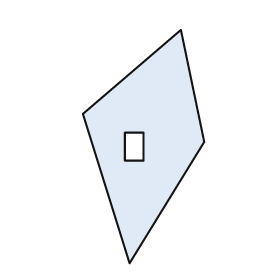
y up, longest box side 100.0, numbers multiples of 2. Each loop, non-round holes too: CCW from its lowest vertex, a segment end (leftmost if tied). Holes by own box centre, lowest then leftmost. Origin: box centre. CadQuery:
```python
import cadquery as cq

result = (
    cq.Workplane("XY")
    .moveTo(-6.0, -50.0)
    .lineTo(26.0, 2.0)
    .lineTo(16.0, 50.0)
    .lineTo(-26.0, 14.0)
    .close()
    .moveTo(-8.0, -6.0)
    .lineTo(0.0, -6.0)
    .lineTo(0.0, 6.0)
    .lineTo(-8.0, 6.0)
    .close()
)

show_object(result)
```